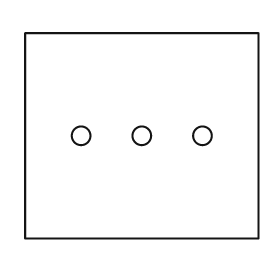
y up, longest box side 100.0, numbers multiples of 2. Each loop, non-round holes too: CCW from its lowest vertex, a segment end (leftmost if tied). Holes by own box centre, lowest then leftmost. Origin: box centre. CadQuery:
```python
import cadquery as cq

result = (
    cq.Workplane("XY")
    .moveTo(-50.0, -44.0)
    .lineTo(50.0, -44.0)
    .lineTo(50.0, 44.0)
    .lineTo(-50.0, 44.0)
    .close()
    .moveTo(-26.0, 0.0)
    .circle(4.0)
    .moveTo(0.0, 0.0)
    .circle(4.0)
    .moveTo(26.0, 0.0)
    .circle(4.0)
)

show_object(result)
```